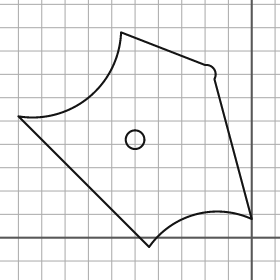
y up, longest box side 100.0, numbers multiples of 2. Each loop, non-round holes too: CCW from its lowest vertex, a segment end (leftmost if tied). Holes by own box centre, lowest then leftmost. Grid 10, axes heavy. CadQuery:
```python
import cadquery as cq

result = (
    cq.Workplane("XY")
    .moveTo(-44.0, -4.0)
    .threePointArc((-24.0, 10.0), (0.0, 8.0))
    .lineTo(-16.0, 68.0)
    .threePointArc((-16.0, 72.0), (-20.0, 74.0))
    .lineTo(-56.0, 88.0)
    .threePointArc((-70.0, 60.0), (-100.0, 52.0))
    .close()
    .moveTo(-50.0, 42.0)
    .circle(4.0)
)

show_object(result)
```